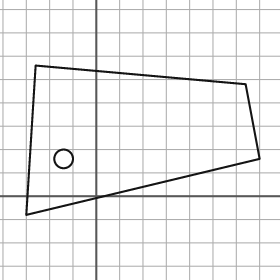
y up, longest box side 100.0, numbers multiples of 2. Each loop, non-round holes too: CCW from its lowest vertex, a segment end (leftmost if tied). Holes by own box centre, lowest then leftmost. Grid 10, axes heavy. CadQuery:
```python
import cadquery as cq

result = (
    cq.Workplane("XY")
    .moveTo(-30.0, -8.0)
    .lineTo(70.0, 16.0)
    .lineTo(64.0, 48.0)
    .lineTo(-26.0, 56.0)
    .close()
    .moveTo(-14.0, 16.0)
    .circle(4.0)
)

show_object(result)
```